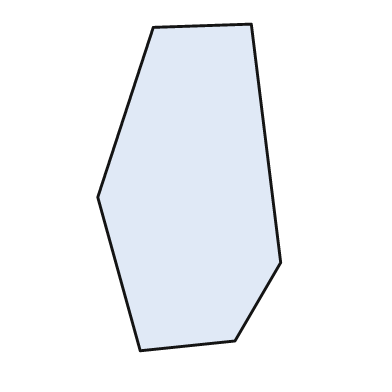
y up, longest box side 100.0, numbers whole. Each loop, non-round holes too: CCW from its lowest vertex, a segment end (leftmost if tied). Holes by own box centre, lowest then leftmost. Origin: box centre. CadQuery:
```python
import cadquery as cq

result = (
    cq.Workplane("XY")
    .moveTo(-15.0, -50.0)
    .lineTo(14.0, -47.0)
    .lineTo(28.0, -23.0)
    .lineTo(19.0, 50.0)
    .lineTo(-11.0, 49.0)
    .lineTo(-28.0, -3.0)
    .close()
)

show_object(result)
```